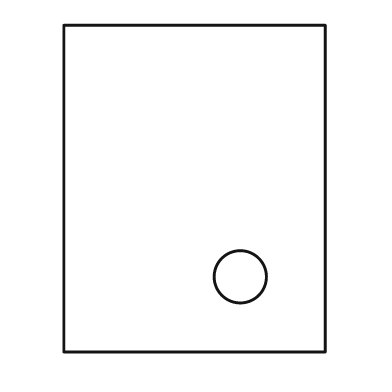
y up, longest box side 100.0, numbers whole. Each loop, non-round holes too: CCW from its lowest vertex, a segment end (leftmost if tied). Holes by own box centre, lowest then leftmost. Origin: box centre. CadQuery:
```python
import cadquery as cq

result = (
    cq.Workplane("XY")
    .moveTo(-40.0, -50.0)
    .lineTo(40.0, -50.0)
    .lineTo(40.0, 50.0)
    .lineTo(-40.0, 50.0)
    .close()
    .moveTo(14.0, -27.0)
    .circle(8.0)
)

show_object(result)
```